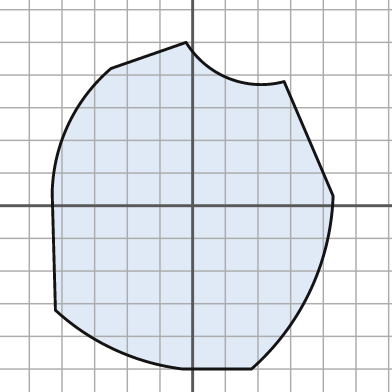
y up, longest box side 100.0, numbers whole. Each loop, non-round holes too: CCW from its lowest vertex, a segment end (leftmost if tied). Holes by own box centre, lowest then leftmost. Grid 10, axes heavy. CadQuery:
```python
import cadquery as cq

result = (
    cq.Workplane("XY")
    .moveTo(-3.0, -50.0)
    .lineTo(18.0, -50.0)
    .threePointArc((36.0, -26.0), (43.0, 3.0))
    .lineTo(28.0, 38.0)
    .threePointArc((11.0, 39.0), (-2.0, 50.0))
    .lineTo(-25.0, 42.0)
    .threePointArc((-38.0, 25.0), (-43.0, 4.0))
    .lineTo(-42.0, -32.0)
    .threePointArc((-24.0, -44.0), (-3.0, -50.0))
    .close()
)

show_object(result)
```